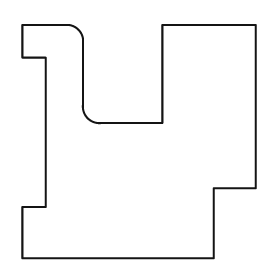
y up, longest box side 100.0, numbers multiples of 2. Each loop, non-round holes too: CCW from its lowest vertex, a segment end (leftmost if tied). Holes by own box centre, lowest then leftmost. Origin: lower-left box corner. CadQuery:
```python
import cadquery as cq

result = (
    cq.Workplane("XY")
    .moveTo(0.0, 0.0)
    .lineTo(82.0, 0.0)
    .lineTo(82.0, 30.0)
    .lineTo(100.0, 30.0)
    .lineTo(100.0, 100.0)
    .lineTo(60.0, 100.0)
    .lineTo(60.0, 58.0)
    .lineTo(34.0, 58.0)
    .threePointArc((28.0, 60.0), (26.0, 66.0))
    .lineTo(26.0, 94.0)
    .threePointArc((24.0, 98.0), (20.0, 100.0))
    .lineTo(0.0, 100.0)
    .lineTo(0.0, 86.0)
    .lineTo(10.0, 86.0)
    .lineTo(10.0, 22.0)
    .lineTo(0.0, 22.0)
    .close()
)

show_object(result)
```